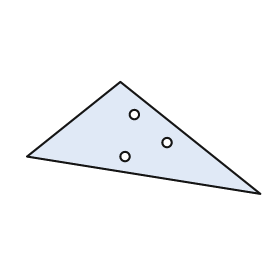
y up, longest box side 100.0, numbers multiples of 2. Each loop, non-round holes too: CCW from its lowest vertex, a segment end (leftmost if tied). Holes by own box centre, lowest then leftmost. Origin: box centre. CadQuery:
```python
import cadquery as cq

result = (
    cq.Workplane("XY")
    .moveTo(50.0, -24.0)
    .lineTo(-10.0, 24.0)
    .lineTo(-50.0, -8.0)
    .close()
    .moveTo(-8.0, -8.0)
    .circle(2.0)
    .moveTo(10.0, -2.0)
    .circle(2.0)
    .moveTo(-4.0, 10.0)
    .circle(2.0)
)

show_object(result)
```